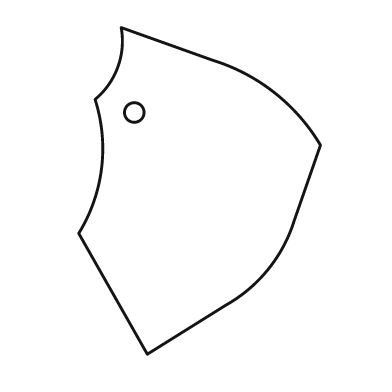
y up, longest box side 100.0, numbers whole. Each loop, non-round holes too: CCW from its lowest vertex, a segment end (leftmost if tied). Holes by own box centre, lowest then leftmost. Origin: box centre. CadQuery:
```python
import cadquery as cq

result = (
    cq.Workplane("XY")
    .moveTo(-16.0, -50.0)
    .lineTo(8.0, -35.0)
    .threePointArc((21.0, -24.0), (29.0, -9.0))
    .lineTo(37.0, 14.0)
    .threePointArc((23.0, 30.0), (4.0, 40.0))
    .lineTo(-24.0, 50.0)
    .threePointArc((-25.0, 38.0), (-32.0, 28.0))
    .threePointArc((-30.0, 7.0), (-37.0, -13.0))
    .close()
    .moveTo(-20.0, 24.0)
    .circle(3.0)
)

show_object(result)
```